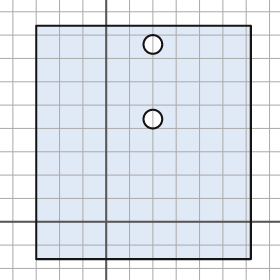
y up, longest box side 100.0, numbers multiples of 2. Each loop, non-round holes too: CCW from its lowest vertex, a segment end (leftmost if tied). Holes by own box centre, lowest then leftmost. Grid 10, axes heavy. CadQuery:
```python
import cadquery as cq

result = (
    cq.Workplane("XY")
    .moveTo(-30.0, -16.0)
    .lineTo(62.0, -16.0)
    .lineTo(62.0, 84.0)
    .lineTo(-30.0, 84.0)
    .close()
    .moveTo(20.0, 44.0)
    .circle(4.0)
    .moveTo(20.0, 76.0)
    .circle(4.0)
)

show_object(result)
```